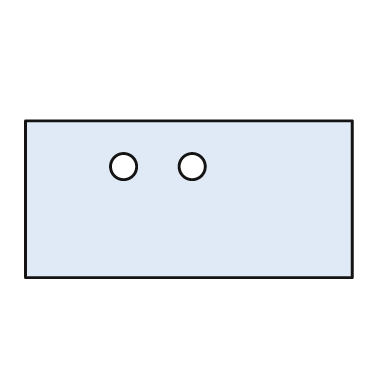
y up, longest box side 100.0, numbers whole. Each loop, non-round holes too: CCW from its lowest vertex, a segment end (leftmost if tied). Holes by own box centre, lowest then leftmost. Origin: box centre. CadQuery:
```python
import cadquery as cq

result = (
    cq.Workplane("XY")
    .moveTo(-50.0, -24.0)
    .lineTo(50.0, -24.0)
    .lineTo(50.0, 24.0)
    .lineTo(-50.0, 24.0)
    .close()
    .moveTo(-20.0, 10.0)
    .circle(4.0)
    .moveTo(1.0, 10.0)
    .circle(4.0)
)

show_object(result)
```